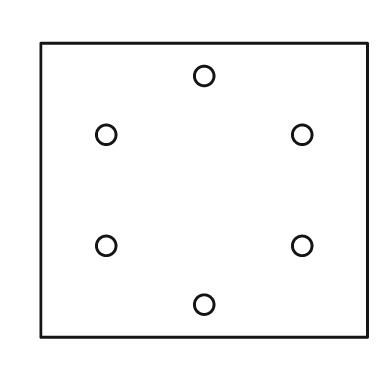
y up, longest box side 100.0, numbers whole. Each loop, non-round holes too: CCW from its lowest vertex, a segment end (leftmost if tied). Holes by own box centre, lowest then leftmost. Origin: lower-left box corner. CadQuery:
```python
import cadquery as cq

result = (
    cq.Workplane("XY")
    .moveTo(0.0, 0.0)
    .lineTo(100.0, 0.0)
    .lineTo(100.0, 90.0)
    .lineTo(0.0, 90.0)
    .close()
    .moveTo(50.0, 10.0)
    .circle(3.0)
    .moveTo(20.0, 28.0)
    .circle(3.0)
    .moveTo(80.0, 28.0)
    .circle(3.0)
    .moveTo(20.0, 62.0)
    .circle(3.0)
    .moveTo(80.0, 62.0)
    .circle(3.0)
    .moveTo(50.0, 80.0)
    .circle(3.0)
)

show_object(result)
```